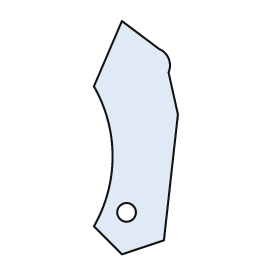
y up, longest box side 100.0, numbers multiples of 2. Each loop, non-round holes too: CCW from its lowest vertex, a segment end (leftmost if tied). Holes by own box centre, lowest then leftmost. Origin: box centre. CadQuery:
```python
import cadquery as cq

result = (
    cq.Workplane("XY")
    .moveTo(-6.0, -50.0)
    .lineTo(12.0, -44.0)
    .lineTo(18.0, 10.0)
    .lineTo(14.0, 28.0)
    .threePointArc((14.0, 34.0), (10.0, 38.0))
    .lineTo(-6.0, 50.0)
    .lineTo(-18.0, 22.0)
    .threePointArc((-10.0, -8.0), (-18.0, -38.0))
    .close()
    .moveTo(-4.0, -32.0)
    .circle(4.0)
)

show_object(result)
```